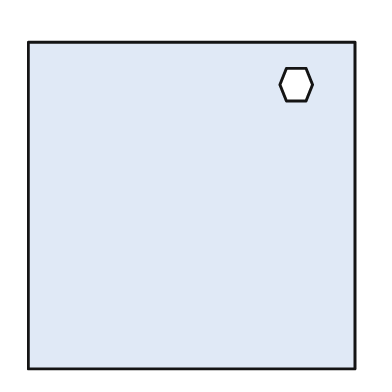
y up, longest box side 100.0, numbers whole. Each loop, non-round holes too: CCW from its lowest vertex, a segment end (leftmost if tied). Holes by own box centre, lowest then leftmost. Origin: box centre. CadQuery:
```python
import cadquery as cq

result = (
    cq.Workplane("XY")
    .moveTo(-50.0, -50.0)
    .lineTo(50.0, -50.0)
    .lineTo(50.0, 50.0)
    .lineTo(-50.0, 50.0)
    .close()
    .moveTo(29.0, 32.0)
    .lineTo(35.0, 32.0)
    .lineTo(37.0, 37.0)
    .lineTo(35.0, 42.0)
    .lineTo(29.0, 42.0)
    .lineTo(27.0, 37.0)
    .close()
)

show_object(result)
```